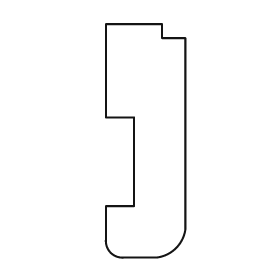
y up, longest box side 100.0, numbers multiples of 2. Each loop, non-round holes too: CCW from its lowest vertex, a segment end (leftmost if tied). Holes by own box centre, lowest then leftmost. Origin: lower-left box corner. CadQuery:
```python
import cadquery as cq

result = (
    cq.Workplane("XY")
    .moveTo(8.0, 0.0)
    .lineTo(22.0, 0.0)
    .threePointArc((30.0, 4.0), (34.0, 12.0))
    .lineTo(34.0, 94.0)
    .lineTo(24.0, 94.0)
    .lineTo(24.0, 100.0)
    .lineTo(0.0, 100.0)
    .lineTo(0.0, 60.0)
    .lineTo(12.0, 60.0)
    .lineTo(12.0, 22.0)
    .lineTo(0.0, 22.0)
    .lineTo(0.0, 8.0)
    .threePointArc((2.0, 2.0), (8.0, 0.0))
    .close()
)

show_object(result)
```